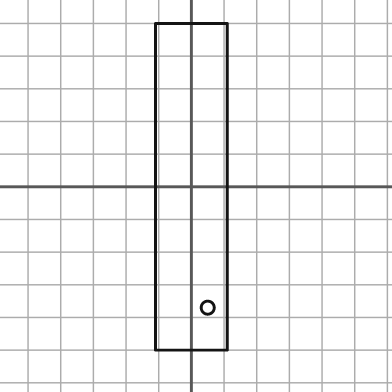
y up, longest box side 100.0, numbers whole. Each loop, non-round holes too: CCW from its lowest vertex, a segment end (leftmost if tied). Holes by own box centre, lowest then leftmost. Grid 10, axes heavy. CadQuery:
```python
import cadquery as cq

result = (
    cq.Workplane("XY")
    .moveTo(-11.0, -50.0)
    .lineTo(11.0, -50.0)
    .lineTo(11.0, 50.0)
    .lineTo(-11.0, 50.0)
    .close()
    .moveTo(5.0, -37.0)
    .circle(2.0)
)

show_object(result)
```